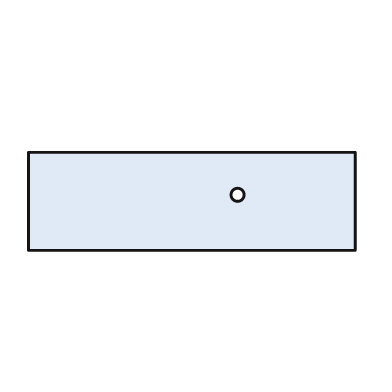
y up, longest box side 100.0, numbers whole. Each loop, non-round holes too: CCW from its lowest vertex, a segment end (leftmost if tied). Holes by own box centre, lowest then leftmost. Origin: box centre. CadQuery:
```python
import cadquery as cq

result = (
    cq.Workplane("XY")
    .moveTo(-50.0, -15.0)
    .lineTo(50.0, -15.0)
    .lineTo(50.0, 15.0)
    .lineTo(-50.0, 15.0)
    .close()
    .moveTo(14.0, 2.0)
    .circle(2.0)
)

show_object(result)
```